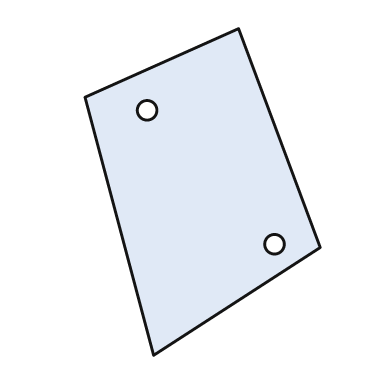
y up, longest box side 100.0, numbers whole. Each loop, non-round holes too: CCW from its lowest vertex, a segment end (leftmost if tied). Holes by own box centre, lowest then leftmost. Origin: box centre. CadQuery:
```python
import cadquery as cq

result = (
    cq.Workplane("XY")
    .moveTo(-15.0, -50.0)
    .lineTo(36.0, -17.0)
    .lineTo(11.0, 50.0)
    .lineTo(-36.0, 29.0)
    .close()
    .moveTo(22.0, -16.0)
    .circle(3.0)
    .moveTo(-17.0, 25.0)
    .circle(3.0)
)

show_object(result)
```